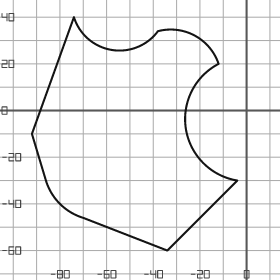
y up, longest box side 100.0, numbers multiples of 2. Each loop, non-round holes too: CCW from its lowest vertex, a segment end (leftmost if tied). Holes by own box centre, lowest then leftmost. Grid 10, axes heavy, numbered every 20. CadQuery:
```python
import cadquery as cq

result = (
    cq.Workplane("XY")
    .moveTo(-34.0, -60.0)
    .lineTo(-4.0, -30.0)
    .threePointArc((-26.0, -8.0), (-12.0, 20.0))
    .threePointArc((-22.0, 32.0), (-38.0, 34.0))
    .threePointArc((-58.0, 26.0), (-74.0, 40.0))
    .lineTo(-92.0, -10.0)
    .lineTo(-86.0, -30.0)
    .threePointArc((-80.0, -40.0), (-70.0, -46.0))
    .close()
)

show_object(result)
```